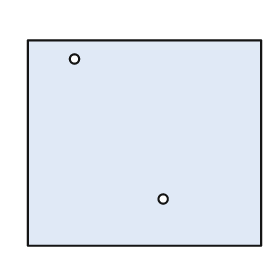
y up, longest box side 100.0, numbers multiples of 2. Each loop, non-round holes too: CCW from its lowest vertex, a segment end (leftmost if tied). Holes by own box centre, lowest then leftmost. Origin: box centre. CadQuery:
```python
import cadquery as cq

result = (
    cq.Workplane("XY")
    .moveTo(-50.0, -44.0)
    .lineTo(50.0, -44.0)
    .lineTo(50.0, 44.0)
    .lineTo(-50.0, 44.0)
    .close()
    .moveTo(8.0, -24.0)
    .circle(2.0)
    .moveTo(-30.0, 36.0)
    .circle(2.0)
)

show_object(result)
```